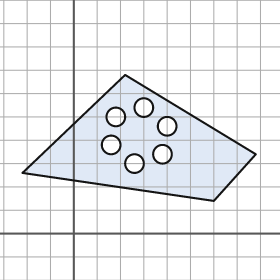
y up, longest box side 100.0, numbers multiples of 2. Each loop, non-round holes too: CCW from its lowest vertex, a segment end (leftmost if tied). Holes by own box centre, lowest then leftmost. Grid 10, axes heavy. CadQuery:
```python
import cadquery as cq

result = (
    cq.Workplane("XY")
    .moveTo(60.0, 14.0)
    .lineTo(78.0, 34.0)
    .lineTo(22.0, 68.0)
    .lineTo(-22.0, 26.0)
    .close()
    .moveTo(26.0, 30.0)
    .circle(4.0)
    .moveTo(38.0, 34.0)
    .circle(4.0)
    .moveTo(16.0, 38.0)
    .circle(4.0)
    .moveTo(40.0, 46.0)
    .circle(4.0)
    .moveTo(18.0, 50.0)
    .circle(4.0)
    .moveTo(30.0, 54.0)
    .circle(4.0)
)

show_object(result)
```